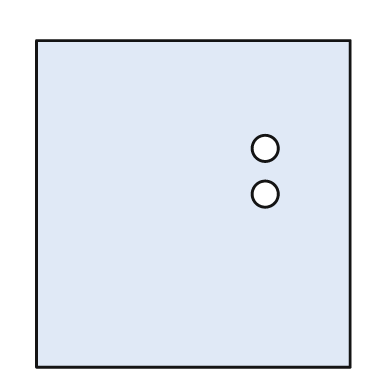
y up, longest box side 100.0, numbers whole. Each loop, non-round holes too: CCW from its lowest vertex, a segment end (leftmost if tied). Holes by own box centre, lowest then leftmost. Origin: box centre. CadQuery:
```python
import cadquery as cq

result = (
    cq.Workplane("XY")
    .moveTo(-48.0, -50.0)
    .lineTo(48.0, -50.0)
    .lineTo(48.0, 50.0)
    .lineTo(-48.0, 50.0)
    .close()
    .moveTo(22.0, 3.0)
    .circle(4.0)
    .moveTo(22.0, 17.0)
    .circle(4.0)
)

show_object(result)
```